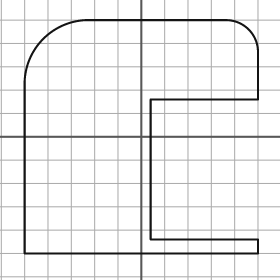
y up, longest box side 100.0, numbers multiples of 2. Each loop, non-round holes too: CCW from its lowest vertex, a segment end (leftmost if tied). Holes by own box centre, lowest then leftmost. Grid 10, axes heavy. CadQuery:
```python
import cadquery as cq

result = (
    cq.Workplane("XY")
    .moveTo(-50.0, -50.0)
    .lineTo(50.0, -50.0)
    .lineTo(50.0, -44.0)
    .lineTo(4.0, -44.0)
    .lineTo(4.0, 16.0)
    .lineTo(50.0, 16.0)
    .lineTo(50.0, 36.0)
    .threePointArc((46.0, 46.0), (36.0, 50.0))
    .lineTo(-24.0, 50.0)
    .threePointArc((-42.0, 42.0), (-50.0, 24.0))
    .close()
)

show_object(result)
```